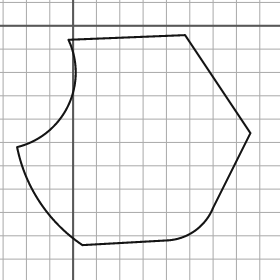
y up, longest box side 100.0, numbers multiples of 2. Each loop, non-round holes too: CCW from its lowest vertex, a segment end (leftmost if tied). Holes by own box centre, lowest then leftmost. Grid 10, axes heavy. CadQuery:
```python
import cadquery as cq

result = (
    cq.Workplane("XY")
    .moveTo(4.0, -94.0)
    .lineTo(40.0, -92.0)
    .threePointArc((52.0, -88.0), (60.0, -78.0))
    .lineTo(76.0, -46.0)
    .lineTo(48.0, -4.0)
    .lineTo(-2.0, -6.0)
    .threePointArc((-2.0, -34.0), (-24.0, -52.0))
    .threePointArc((-14.0, -76.0), (4.0, -94.0))
    .close()
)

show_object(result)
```